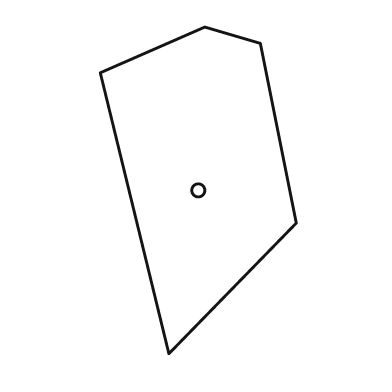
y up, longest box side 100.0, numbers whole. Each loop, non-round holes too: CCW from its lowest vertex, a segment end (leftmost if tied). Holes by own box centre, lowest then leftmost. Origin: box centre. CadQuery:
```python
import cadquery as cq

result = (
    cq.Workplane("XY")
    .moveTo(-9.0, -50.0)
    .lineTo(30.0, -10.0)
    .lineTo(19.0, 45.0)
    .lineTo(2.0, 50.0)
    .lineTo(-30.0, 36.0)
    .close()
    .moveTo(0.0, 0.0)
    .circle(2.0)
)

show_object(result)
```